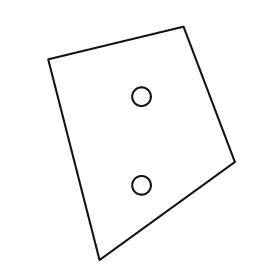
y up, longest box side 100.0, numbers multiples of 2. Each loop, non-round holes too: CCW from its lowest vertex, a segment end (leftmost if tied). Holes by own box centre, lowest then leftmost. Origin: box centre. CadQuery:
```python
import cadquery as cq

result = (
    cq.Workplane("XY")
    .moveTo(-18.0, -50.0)
    .lineTo(40.0, -8.0)
    .lineTo(18.0, 50.0)
    .lineTo(-40.0, 36.0)
    .close()
    .moveTo(0.0, -18.0)
    .circle(4.0)
    .moveTo(0.0, 20.0)
    .circle(4.0)
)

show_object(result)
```